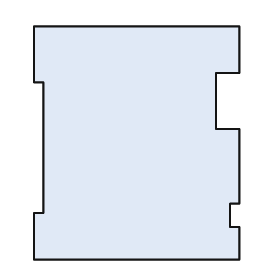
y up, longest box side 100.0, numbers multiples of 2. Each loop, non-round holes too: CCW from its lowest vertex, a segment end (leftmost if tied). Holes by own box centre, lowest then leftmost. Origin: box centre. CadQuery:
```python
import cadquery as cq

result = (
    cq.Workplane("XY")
    .moveTo(-44.0, -50.0)
    .lineTo(44.0, -50.0)
    .lineTo(44.0, -36.0)
    .lineTo(40.0, -36.0)
    .lineTo(40.0, -26.0)
    .lineTo(44.0, -26.0)
    .lineTo(44.0, 6.0)
    .lineTo(34.0, 6.0)
    .lineTo(34.0, 30.0)
    .lineTo(44.0, 30.0)
    .lineTo(44.0, 50.0)
    .lineTo(-44.0, 50.0)
    .lineTo(-44.0, 26.0)
    .lineTo(-40.0, 26.0)
    .lineTo(-40.0, -30.0)
    .lineTo(-44.0, -30.0)
    .close()
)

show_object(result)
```